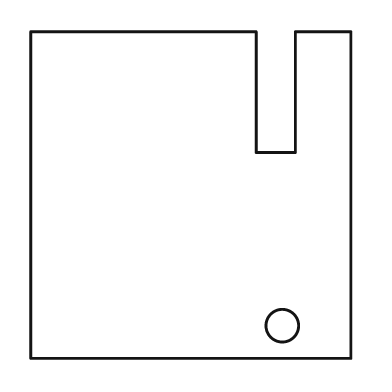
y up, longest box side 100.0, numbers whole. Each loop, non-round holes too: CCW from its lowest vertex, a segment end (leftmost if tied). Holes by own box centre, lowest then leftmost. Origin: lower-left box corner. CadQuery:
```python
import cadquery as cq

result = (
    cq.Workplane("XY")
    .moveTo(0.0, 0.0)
    .lineTo(98.0, 0.0)
    .lineTo(98.0, 100.0)
    .lineTo(81.0, 100.0)
    .lineTo(81.0, 63.0)
    .lineTo(69.0, 63.0)
    .lineTo(69.0, 100.0)
    .lineTo(0.0, 100.0)
    .close()
    .moveTo(77.0, 10.0)
    .circle(5.0)
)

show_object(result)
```